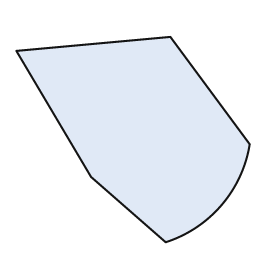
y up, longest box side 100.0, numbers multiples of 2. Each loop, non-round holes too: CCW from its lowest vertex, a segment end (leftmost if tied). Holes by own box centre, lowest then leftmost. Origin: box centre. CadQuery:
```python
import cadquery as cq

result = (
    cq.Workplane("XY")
    .moveTo(14.0, -44.0)
    .threePointArc((38.0, -28.0), (50.0, -2.0))
    .lineTo(16.0, 44.0)
    .lineTo(-50.0, 38.0)
    .lineTo(-18.0, -16.0)
    .close()
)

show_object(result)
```